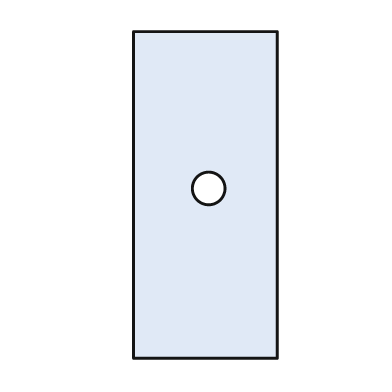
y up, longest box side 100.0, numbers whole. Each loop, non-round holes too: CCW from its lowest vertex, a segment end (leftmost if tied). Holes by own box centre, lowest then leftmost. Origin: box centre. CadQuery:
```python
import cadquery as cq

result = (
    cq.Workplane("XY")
    .moveTo(-22.0, -50.0)
    .lineTo(22.0, -50.0)
    .lineTo(22.0, 50.0)
    .lineTo(-22.0, 50.0)
    .close()
    .moveTo(1.0, 2.0)
    .circle(5.0)
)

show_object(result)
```